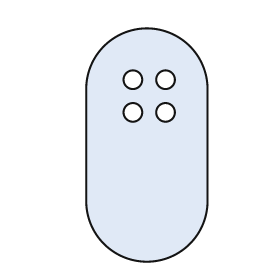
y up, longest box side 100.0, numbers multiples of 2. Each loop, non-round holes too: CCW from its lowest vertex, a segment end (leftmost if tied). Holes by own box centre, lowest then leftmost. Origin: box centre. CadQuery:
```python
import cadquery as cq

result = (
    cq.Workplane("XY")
    .moveTo(-26.0, -24.0)
    .threePointArc((0.0, -50.0), (26.0, -24.0))
    .lineTo(26.0, 24.0)
    .threePointArc((0.0, 50.0), (-26.0, 24.0))
    .close()
    .moveTo(-6.0, 14.0)
    .circle(4.0)
    .moveTo(8.0, 14.0)
    .circle(4.0)
    .moveTo(-6.0, 28.0)
    .circle(4.0)
    .moveTo(8.0, 28.0)
    .circle(4.0)
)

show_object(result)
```